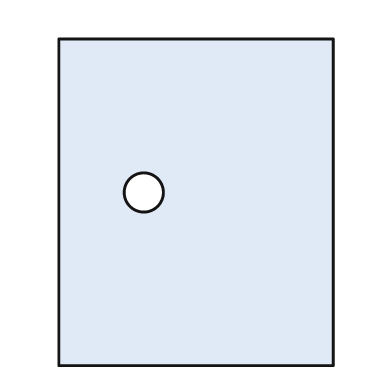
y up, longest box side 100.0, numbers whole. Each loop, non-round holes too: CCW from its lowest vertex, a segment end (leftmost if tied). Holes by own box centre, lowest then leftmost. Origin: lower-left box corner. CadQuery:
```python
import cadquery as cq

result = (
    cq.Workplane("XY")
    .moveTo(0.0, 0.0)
    .lineTo(84.0, 0.0)
    .lineTo(84.0, 100.0)
    .lineTo(0.0, 100.0)
    .close()
    .moveTo(26.0, 53.0)
    .circle(6.0)
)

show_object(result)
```